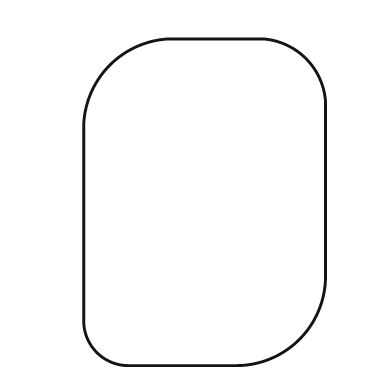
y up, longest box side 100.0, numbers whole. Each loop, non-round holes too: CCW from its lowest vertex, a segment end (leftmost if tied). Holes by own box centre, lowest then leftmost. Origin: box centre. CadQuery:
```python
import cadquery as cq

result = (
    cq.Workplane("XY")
    .moveTo(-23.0, -50.0)
    .lineTo(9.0, -50.0)
    .threePointArc((29.0, -42.0), (37.0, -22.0))
    .lineTo(37.0, 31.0)
    .threePointArc((31.0, 44.0), (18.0, 50.0))
    .lineTo(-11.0, 50.0)
    .threePointArc((-29.0, 42.0), (-37.0, 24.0))
    .lineTo(-37.0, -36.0)
    .threePointArc((-33.0, -46.0), (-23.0, -50.0))
    .close()
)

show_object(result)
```